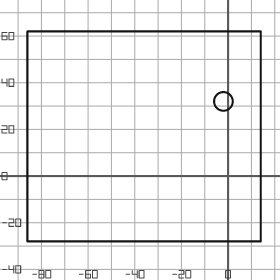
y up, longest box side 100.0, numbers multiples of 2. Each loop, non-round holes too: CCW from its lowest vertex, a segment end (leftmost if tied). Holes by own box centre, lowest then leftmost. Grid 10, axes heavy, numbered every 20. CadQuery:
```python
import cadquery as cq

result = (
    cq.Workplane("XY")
    .moveTo(-86.0, -28.0)
    .lineTo(14.0, -28.0)
    .lineTo(14.0, 62.0)
    .lineTo(-86.0, 62.0)
    .close()
    .moveTo(-2.0, 32.0)
    .circle(4.0)
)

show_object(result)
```